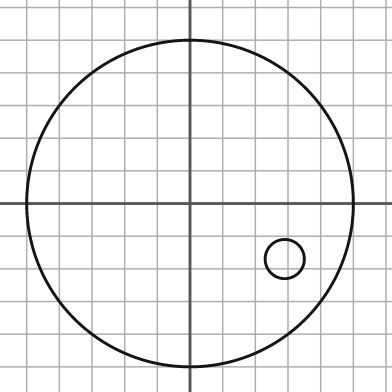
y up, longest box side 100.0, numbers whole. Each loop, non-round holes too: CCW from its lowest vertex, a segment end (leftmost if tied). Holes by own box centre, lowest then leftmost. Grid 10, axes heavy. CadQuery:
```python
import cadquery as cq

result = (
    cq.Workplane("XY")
    .moveTo(0.0, 0.0)
    .circle(50.0)
    .moveTo(29.0, -17.0)
    .circle(6.0)
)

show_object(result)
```